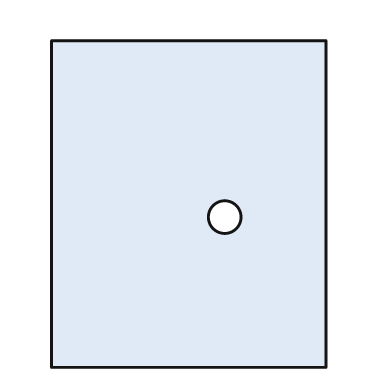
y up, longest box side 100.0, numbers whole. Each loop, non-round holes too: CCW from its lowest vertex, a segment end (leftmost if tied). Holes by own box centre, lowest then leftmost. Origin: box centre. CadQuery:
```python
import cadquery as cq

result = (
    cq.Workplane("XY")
    .moveTo(-42.0, -50.0)
    .lineTo(42.0, -50.0)
    .lineTo(42.0, 50.0)
    .lineTo(-42.0, 50.0)
    .close()
    .moveTo(11.0, -4.0)
    .circle(5.0)
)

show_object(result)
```